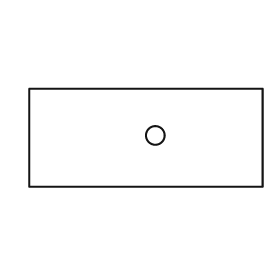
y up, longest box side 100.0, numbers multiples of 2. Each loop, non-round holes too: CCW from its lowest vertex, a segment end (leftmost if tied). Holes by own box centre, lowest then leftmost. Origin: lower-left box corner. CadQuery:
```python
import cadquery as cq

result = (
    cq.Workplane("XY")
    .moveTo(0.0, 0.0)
    .lineTo(100.0, 0.0)
    .lineTo(100.0, 42.0)
    .lineTo(0.0, 42.0)
    .close()
    .moveTo(54.0, 22.0)
    .circle(4.0)
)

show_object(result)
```